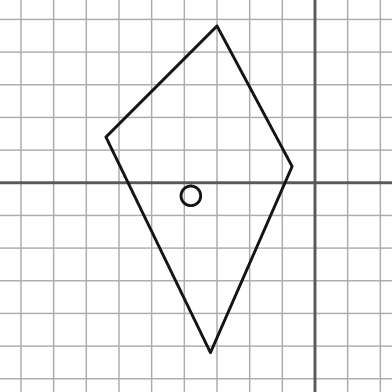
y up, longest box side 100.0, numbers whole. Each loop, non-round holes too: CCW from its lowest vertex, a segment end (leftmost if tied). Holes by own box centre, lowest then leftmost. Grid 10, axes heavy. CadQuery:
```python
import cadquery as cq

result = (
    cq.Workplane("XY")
    .moveTo(-32.0, -52.0)
    .lineTo(-7.0, 5.0)
    .lineTo(-30.0, 48.0)
    .lineTo(-64.0, 14.0)
    .close()
    .moveTo(-38.0, -4.0)
    .circle(3.0)
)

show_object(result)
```